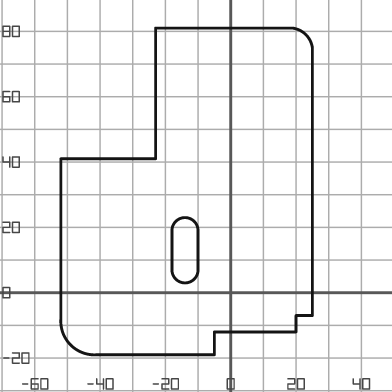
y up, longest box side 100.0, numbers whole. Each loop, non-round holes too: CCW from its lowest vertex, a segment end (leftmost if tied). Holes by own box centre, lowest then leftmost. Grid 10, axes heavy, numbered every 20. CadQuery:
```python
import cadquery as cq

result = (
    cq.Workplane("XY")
    .moveTo(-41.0, -19.0)
    .lineTo(-5.0, -19.0)
    .lineTo(-5.0, -12.0)
    .lineTo(20.0, -12.0)
    .lineTo(20.0, -7.0)
    .lineTo(25.0, -7.0)
    .lineTo(25.0, 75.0)
    .threePointArc((23.0, 79.0), (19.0, 81.0))
    .lineTo(-23.0, 81.0)
    .lineTo(-23.0, 41.0)
    .lineTo(-52.0, 41.0)
    .lineTo(-52.0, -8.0)
    .threePointArc((-49.0, -16.0), (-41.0, -19.0))
    .close()
    .moveTo(-18.0, 7.0)
    .threePointArc((-14.0, 3.0), (-10.0, 7.0))
    .lineTo(-10.0, 19.0)
    .threePointArc((-14.0, 23.0), (-18.0, 19.0))
    .close()
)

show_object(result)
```